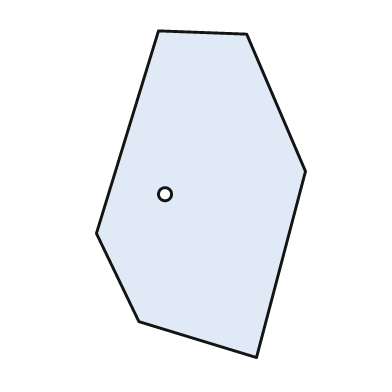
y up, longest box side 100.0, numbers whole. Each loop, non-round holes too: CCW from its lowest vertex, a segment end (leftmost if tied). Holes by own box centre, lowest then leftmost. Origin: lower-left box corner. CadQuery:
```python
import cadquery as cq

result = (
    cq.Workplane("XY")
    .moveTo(49.0, 0.0)
    .lineTo(64.0, 57.0)
    .lineTo(46.0, 99.0)
    .lineTo(19.0, 100.0)
    .lineTo(0.0, 38.0)
    .lineTo(13.0, 11.0)
    .close()
    .moveTo(21.0, 50.0)
    .circle(2.0)
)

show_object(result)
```